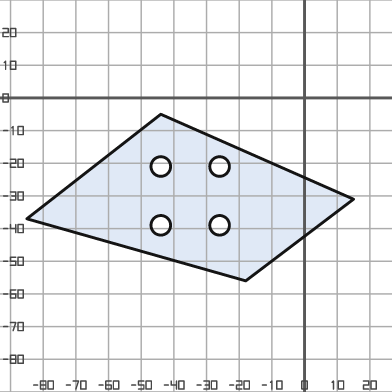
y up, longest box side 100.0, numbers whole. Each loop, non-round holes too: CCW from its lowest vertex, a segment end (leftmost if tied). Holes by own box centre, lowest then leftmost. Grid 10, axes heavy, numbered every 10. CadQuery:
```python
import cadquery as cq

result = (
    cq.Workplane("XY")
    .moveTo(-18.0, -56.0)
    .lineTo(15.0, -31.0)
    .lineTo(-44.0, -5.0)
    .lineTo(-85.0, -37.0)
    .close()
    .moveTo(-44.0, -39.0)
    .circle(3.0)
    .moveTo(-26.0, -39.0)
    .circle(3.0)
    .moveTo(-44.0, -21.0)
    .circle(3.0)
    .moveTo(-26.0, -21.0)
    .circle(3.0)
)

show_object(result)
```